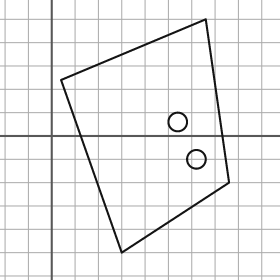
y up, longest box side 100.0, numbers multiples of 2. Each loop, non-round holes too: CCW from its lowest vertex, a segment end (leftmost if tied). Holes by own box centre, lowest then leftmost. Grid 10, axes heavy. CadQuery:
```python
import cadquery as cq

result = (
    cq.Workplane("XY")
    .moveTo(30.0, -50.0)
    .lineTo(76.0, -20.0)
    .lineTo(66.0, 50.0)
    .lineTo(4.0, 24.0)
    .close()
    .moveTo(62.0, -10.0)
    .circle(4.0)
    .moveTo(54.0, 6.0)
    .circle(4.0)
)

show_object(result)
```